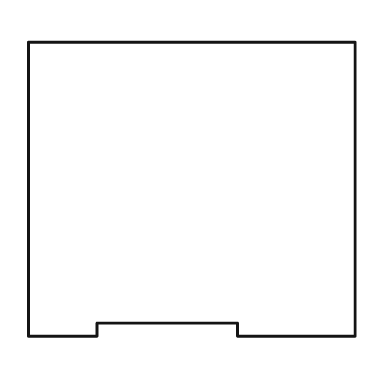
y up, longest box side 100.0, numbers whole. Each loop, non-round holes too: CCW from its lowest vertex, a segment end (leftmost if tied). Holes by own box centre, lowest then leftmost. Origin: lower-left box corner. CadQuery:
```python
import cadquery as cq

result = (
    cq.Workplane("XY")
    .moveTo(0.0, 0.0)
    .lineTo(21.0, 0.0)
    .lineTo(21.0, 4.0)
    .lineTo(64.0, 4.0)
    .lineTo(64.0, 0.0)
    .lineTo(100.0, 0.0)
    .lineTo(100.0, 90.0)
    .lineTo(0.0, 90.0)
    .close()
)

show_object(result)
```